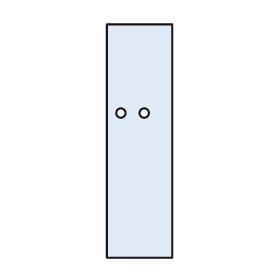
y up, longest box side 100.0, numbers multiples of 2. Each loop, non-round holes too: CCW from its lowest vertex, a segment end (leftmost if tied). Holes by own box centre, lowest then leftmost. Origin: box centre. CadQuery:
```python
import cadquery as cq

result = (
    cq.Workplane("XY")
    .moveTo(-14.0, -50.0)
    .lineTo(14.0, -50.0)
    .lineTo(14.0, 50.0)
    .lineTo(-14.0, 50.0)
    .close()
    .moveTo(-8.0, 12.0)
    .circle(2.0)
    .moveTo(2.0, 12.0)
    .circle(2.0)
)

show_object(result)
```